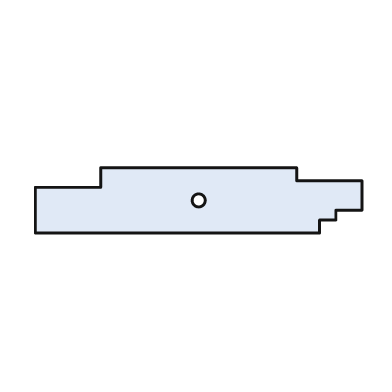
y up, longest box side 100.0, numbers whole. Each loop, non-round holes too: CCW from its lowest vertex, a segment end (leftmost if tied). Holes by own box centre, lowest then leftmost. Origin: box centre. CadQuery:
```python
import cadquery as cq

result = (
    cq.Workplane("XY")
    .moveTo(-50.0, -10.0)
    .lineTo(37.0, -10.0)
    .lineTo(37.0, -6.0)
    .lineTo(42.0, -6.0)
    .lineTo(42.0, -3.0)
    .lineTo(50.0, -3.0)
    .lineTo(50.0, 6.0)
    .lineTo(30.0, 6.0)
    .lineTo(30.0, 10.0)
    .lineTo(-30.0, 10.0)
    .lineTo(-30.0, 4.0)
    .lineTo(-50.0, 4.0)
    .close()
    .moveTo(0.0, 0.0)
    .circle(2.0)
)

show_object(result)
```